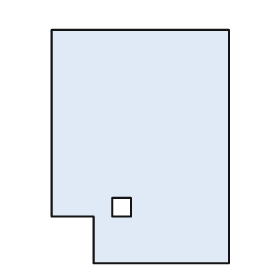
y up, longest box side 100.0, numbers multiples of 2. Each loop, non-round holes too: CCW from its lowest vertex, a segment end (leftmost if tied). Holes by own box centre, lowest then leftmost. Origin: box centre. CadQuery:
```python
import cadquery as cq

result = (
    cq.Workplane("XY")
    .moveTo(-20.0, -50.0)
    .lineTo(38.0, -50.0)
    .lineTo(38.0, 50.0)
    .lineTo(-38.0, 50.0)
    .lineTo(-38.0, -30.0)
    .lineTo(-20.0, -30.0)
    .close()
    .moveTo(-12.0, -30.0)
    .lineTo(-4.0, -30.0)
    .lineTo(-4.0, -22.0)
    .lineTo(-12.0, -22.0)
    .close()
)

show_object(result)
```